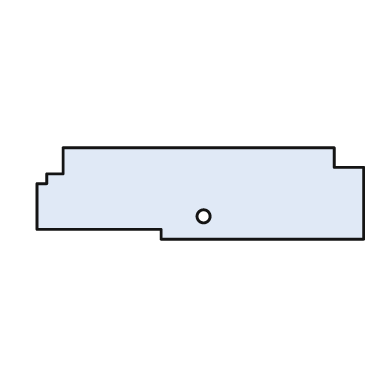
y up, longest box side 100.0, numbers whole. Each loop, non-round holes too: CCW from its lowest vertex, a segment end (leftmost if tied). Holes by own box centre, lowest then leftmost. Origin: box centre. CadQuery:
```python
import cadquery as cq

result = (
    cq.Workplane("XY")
    .moveTo(-12.0, -14.0)
    .lineTo(50.0, -14.0)
    .lineTo(50.0, 8.0)
    .lineTo(41.0, 8.0)
    .lineTo(41.0, 14.0)
    .lineTo(-42.0, 14.0)
    .lineTo(-42.0, 6.0)
    .lineTo(-47.0, 6.0)
    .lineTo(-47.0, 3.0)
    .lineTo(-50.0, 3.0)
    .lineTo(-50.0, -11.0)
    .lineTo(-12.0, -11.0)
    .close()
    .moveTo(1.0, -7.0)
    .circle(2.0)
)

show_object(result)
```